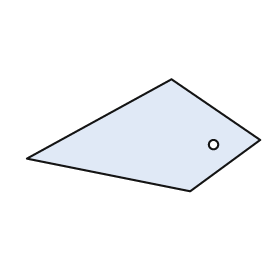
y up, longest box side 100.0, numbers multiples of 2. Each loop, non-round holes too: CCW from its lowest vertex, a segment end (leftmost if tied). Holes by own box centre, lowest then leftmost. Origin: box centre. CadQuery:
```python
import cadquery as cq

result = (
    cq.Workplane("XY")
    .moveTo(20.0, -24.0)
    .lineTo(50.0, -2.0)
    .lineTo(12.0, 24.0)
    .lineTo(-50.0, -10.0)
    .close()
    .moveTo(30.0, -4.0)
    .circle(2.0)
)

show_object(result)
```